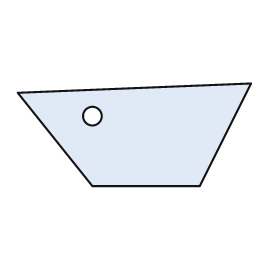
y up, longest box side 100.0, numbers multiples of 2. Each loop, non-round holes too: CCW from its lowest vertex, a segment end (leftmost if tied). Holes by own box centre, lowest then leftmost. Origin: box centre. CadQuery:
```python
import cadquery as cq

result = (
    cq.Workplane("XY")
    .moveTo(-18.0, -22.0)
    .lineTo(28.0, -22.0)
    .lineTo(50.0, 22.0)
    .lineTo(-50.0, 18.0)
    .close()
    .moveTo(-18.0, 8.0)
    .circle(4.0)
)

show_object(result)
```